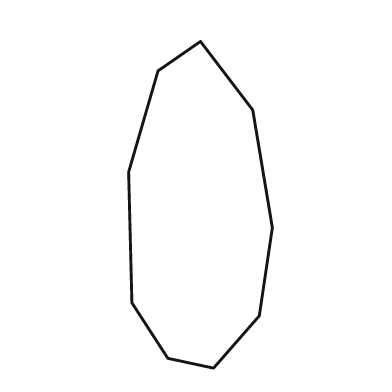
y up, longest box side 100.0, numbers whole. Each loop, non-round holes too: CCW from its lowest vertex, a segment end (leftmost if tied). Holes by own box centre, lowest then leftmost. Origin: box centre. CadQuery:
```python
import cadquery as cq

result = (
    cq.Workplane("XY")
    .moveTo(4.0, -50.0)
    .lineTo(18.0, -34.0)
    .lineTo(22.0, -7.0)
    .lineTo(16.0, 29.0)
    .lineTo(0.0, 50.0)
    .lineTo(-13.0, 41.0)
    .lineTo(-22.0, 10.0)
    .lineTo(-21.0, -30.0)
    .lineTo(-10.0, -47.0)
    .close()
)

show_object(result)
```